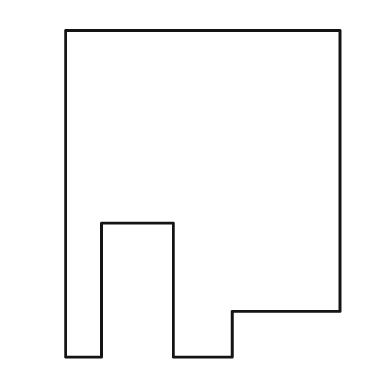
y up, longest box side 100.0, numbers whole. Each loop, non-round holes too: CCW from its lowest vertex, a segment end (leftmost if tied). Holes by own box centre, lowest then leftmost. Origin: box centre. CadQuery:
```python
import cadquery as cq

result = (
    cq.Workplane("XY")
    .moveTo(-42.0, -50.0)
    .lineTo(-31.0, -50.0)
    .lineTo(-31.0, -9.0)
    .lineTo(-9.0, -9.0)
    .lineTo(-9.0, -50.0)
    .lineTo(9.0, -50.0)
    .lineTo(9.0, -36.0)
    .lineTo(42.0, -36.0)
    .lineTo(42.0, 50.0)
    .lineTo(-42.0, 50.0)
    .close()
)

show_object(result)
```